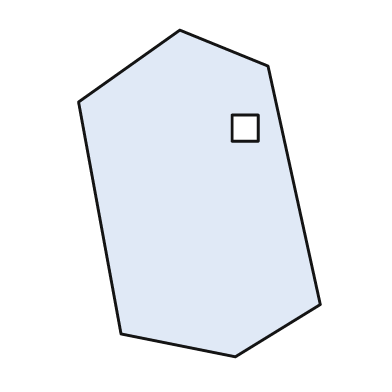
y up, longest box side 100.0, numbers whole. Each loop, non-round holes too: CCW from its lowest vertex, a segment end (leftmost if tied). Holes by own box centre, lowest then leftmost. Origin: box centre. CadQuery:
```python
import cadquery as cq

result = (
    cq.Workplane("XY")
    .moveTo(11.0, -50.0)
    .lineTo(37.0, -34.0)
    .lineTo(21.0, 39.0)
    .lineTo(-6.0, 50.0)
    .lineTo(-37.0, 28.0)
    .lineTo(-24.0, -43.0)
    .close()
    .moveTo(10.0, 16.0)
    .lineTo(18.0, 16.0)
    .lineTo(18.0, 24.0)
    .lineTo(10.0, 24.0)
    .close()
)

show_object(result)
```